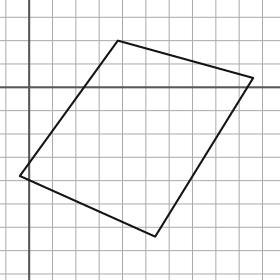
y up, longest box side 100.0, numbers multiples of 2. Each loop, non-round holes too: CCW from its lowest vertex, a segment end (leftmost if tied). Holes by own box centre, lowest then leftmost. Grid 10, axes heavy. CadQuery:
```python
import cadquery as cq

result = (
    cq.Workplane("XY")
    .moveTo(54.0, -64.0)
    .lineTo(96.0, 4.0)
    .lineTo(38.0, 20.0)
    .lineTo(-4.0, -38.0)
    .close()
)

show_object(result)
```